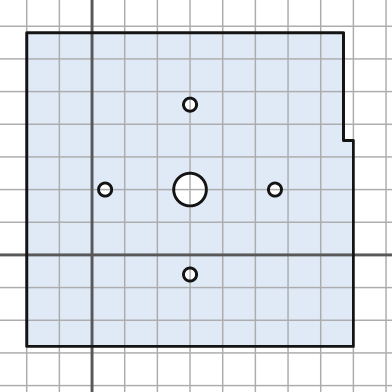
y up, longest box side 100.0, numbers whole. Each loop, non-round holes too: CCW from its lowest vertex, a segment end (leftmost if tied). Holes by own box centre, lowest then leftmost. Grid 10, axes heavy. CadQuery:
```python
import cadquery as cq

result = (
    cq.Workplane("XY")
    .moveTo(-20.0, -28.0)
    .lineTo(80.0, -28.0)
    .lineTo(80.0, 35.0)
    .lineTo(77.0, 35.0)
    .lineTo(77.0, 68.0)
    .lineTo(-20.0, 68.0)
    .close()
    .moveTo(30.0, -6.0)
    .circle(2.0)
    .moveTo(4.0, 20.0)
    .circle(2.0)
    .moveTo(30.0, 20.0)
    .circle(5.0)
    .moveTo(56.0, 20.0)
    .circle(2.0)
    .moveTo(30.0, 46.0)
    .circle(2.0)
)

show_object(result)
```